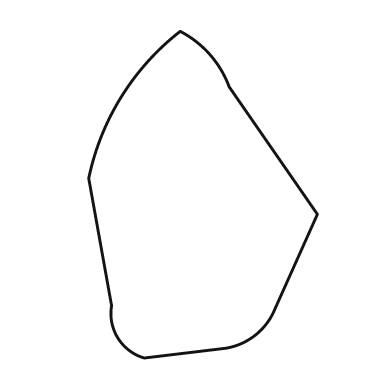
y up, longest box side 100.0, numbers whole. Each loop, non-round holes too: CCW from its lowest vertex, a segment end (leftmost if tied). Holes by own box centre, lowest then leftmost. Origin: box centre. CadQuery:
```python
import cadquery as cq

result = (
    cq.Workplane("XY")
    .moveTo(-18.0, -50.0)
    .lineTo(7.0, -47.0)
    .threePointArc((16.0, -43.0), (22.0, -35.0))
    .lineTo(35.0, -6.0)
    .lineTo(8.0, 33.0)
    .threePointArc((2.0, 43.0), (-7.0, 50.0))
    .threePointArc((-25.0, 30.0), (-35.0, 5.0))
    .lineTo(-28.0, -34.0)
    .threePointArc((-26.0, -44.0), (-18.0, -50.0))
    .close()
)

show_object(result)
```